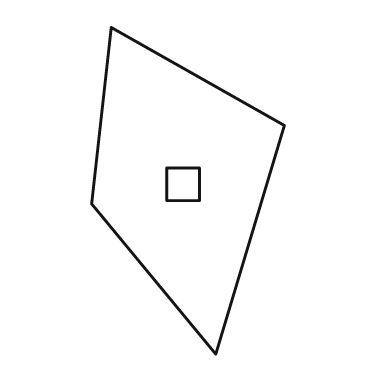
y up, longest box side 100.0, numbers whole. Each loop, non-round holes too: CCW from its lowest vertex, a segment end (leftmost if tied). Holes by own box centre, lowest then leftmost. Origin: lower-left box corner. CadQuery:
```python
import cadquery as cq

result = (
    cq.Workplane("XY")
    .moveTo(38.0, 0.0)
    .lineTo(59.0, 70.0)
    .lineTo(6.0, 100.0)
    .lineTo(0.0, 46.0)
    .close()
    .moveTo(23.0, 47.0)
    .lineTo(33.0, 47.0)
    .lineTo(33.0, 57.0)
    .lineTo(23.0, 57.0)
    .close()
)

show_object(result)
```